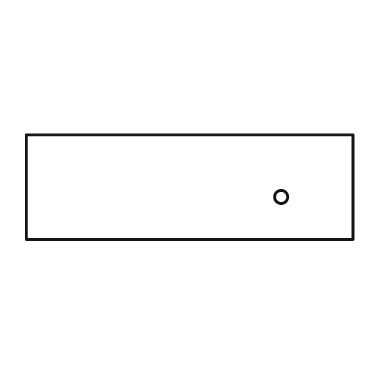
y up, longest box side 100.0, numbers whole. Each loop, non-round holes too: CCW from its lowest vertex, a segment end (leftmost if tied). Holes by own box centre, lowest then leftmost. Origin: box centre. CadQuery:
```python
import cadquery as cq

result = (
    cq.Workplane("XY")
    .moveTo(-50.0, -16.0)
    .lineTo(50.0, -16.0)
    .lineTo(50.0, 16.0)
    .lineTo(-50.0, 16.0)
    .close()
    .moveTo(28.0, -3.0)
    .circle(2.0)
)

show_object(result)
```